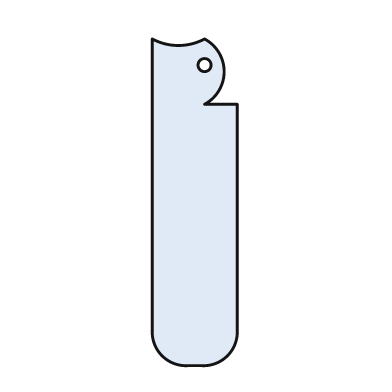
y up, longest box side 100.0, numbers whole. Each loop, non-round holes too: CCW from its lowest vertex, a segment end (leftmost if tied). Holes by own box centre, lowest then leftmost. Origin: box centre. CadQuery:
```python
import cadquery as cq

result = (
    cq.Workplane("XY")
    .moveTo(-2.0, -50.0)
    .lineTo(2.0, -50.0)
    .threePointArc((10.0, -47.0), (13.0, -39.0))
    .lineTo(13.0, 30.0)
    .lineTo(3.0, 30.0)
    .threePointArc((9.0, 40.0), (3.0, 50.0))
    .threePointArc((-5.0, 48.0), (-13.0, 50.0))
    .lineTo(-13.0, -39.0)
    .threePointArc((-10.0, -47.0), (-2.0, -50.0))
    .close()
    .moveTo(3.0, 42.0)
    .circle(2.0)
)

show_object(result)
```